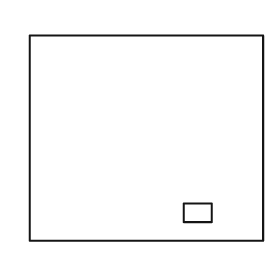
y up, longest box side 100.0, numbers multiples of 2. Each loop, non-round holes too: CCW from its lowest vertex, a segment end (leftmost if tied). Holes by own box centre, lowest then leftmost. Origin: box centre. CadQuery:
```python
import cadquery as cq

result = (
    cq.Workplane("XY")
    .moveTo(-50.0, -44.0)
    .lineTo(50.0, -44.0)
    .lineTo(50.0, 44.0)
    .lineTo(-50.0, 44.0)
    .close()
    .moveTo(16.0, -36.0)
    .lineTo(28.0, -36.0)
    .lineTo(28.0, -28.0)
    .lineTo(16.0, -28.0)
    .close()
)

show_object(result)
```